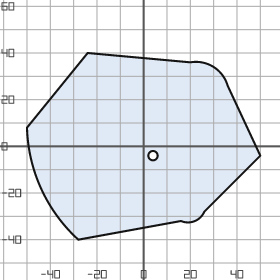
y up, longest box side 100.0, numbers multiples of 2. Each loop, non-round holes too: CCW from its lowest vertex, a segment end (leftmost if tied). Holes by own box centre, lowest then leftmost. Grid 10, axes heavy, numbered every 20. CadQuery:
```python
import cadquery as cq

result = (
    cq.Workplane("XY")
    .moveTo(-28.0, -40.0)
    .lineTo(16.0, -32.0)
    .threePointArc((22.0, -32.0), (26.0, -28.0))
    .lineTo(50.0, -4.0)
    .lineTo(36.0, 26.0)
    .threePointArc((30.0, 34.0), (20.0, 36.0))
    .lineTo(-24.0, 40.0)
    .lineTo(-50.0, 8.0)
    .threePointArc((-44.0, -18.0), (-28.0, -40.0))
    .close()
    .moveTo(4.0, -4.0)
    .circle(2.0)
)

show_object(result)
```